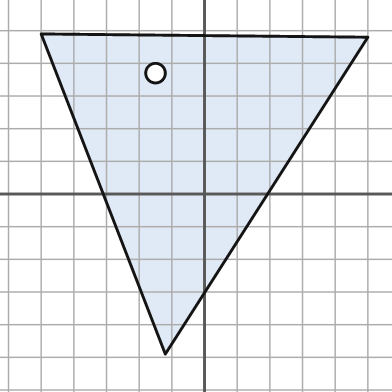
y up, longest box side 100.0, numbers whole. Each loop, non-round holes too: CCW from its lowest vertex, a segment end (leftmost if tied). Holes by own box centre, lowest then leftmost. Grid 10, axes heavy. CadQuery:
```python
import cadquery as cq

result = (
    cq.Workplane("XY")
    .moveTo(-12.0, -49.0)
    .lineTo(50.0, 48.0)
    .lineTo(-50.0, 49.0)
    .close()
    .moveTo(-15.0, 37.0)
    .circle(3.0)
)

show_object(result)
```